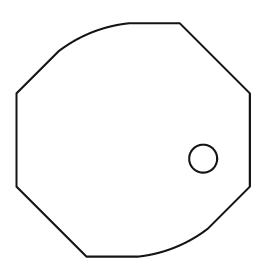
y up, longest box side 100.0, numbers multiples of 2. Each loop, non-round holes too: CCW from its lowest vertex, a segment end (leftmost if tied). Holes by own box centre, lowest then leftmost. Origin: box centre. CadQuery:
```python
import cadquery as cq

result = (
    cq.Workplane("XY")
    .moveTo(-20.0, -50.0)
    .lineTo(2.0, -50.0)
    .threePointArc((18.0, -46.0), (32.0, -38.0))
    .lineTo(50.0, -20.0)
    .lineTo(50.0, 20.0)
    .lineTo(20.0, 50.0)
    .lineTo(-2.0, 50.0)
    .threePointArc((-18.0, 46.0), (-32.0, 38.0))
    .lineTo(-50.0, 20.0)
    .lineTo(-50.0, -20.0)
    .close()
    .moveTo(30.0, -8.0)
    .circle(6.0)
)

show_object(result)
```